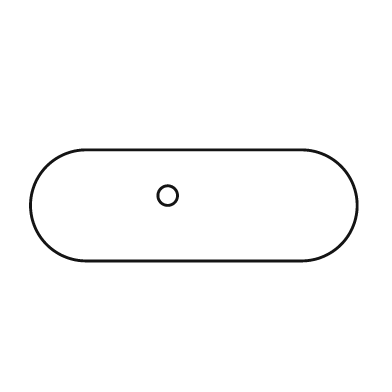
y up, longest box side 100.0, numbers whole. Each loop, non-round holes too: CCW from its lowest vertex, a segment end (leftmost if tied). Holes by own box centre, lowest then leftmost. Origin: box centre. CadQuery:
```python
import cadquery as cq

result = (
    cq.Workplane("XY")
    .moveTo(-33.0, -17.0)
    .lineTo(33.0, -17.0)
    .threePointArc((50.0, 0.0), (33.0, 17.0))
    .lineTo(-33.0, 17.0)
    .threePointArc((-50.0, 0.0), (-33.0, -17.0))
    .close()
    .moveTo(-8.0, 3.0)
    .circle(3.0)
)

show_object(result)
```